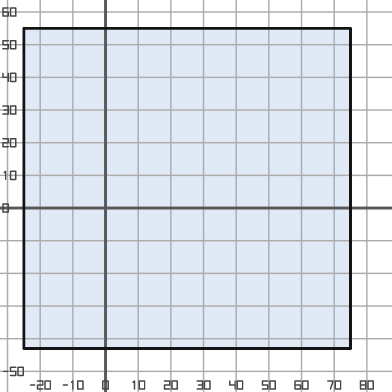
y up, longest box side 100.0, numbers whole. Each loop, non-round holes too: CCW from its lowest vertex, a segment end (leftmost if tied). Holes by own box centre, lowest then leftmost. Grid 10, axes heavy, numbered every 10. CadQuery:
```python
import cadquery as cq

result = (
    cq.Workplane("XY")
    .moveTo(-25.0, -43.0)
    .lineTo(75.0, -43.0)
    .lineTo(75.0, 55.0)
    .lineTo(-25.0, 55.0)
    .close()
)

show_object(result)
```